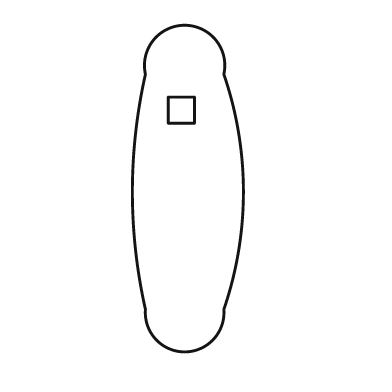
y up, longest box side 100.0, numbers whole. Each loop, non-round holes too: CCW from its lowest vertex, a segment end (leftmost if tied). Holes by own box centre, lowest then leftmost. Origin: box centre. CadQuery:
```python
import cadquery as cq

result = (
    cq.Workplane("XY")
    .moveTo(-13.0, -37.0)
    .threePointArc((-1.0, -50.0), (11.0, -37.0))
    .threePointArc((17.0, -1.0), (11.0, 35.0))
    .threePointArc((-1.0, 50.0), (-13.0, 35.0))
    .threePointArc((-17.0, -1.0), (-13.0, -37.0))
    .close()
    .moveTo(-6.0, 20.0)
    .lineTo(2.0, 20.0)
    .lineTo(2.0, 28.0)
    .lineTo(-6.0, 28.0)
    .close()
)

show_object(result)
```